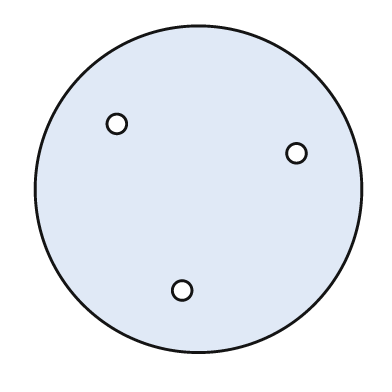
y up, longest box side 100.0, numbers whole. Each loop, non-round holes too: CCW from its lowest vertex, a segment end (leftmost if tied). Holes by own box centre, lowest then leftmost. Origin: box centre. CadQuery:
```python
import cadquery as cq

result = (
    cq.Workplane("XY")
    .moveTo(0.0, 0.0)
    .circle(50.0)
    .moveTo(-5.0, -31.0)
    .circle(3.0)
    .moveTo(30.0, 11.0)
    .circle(3.0)
    .moveTo(-25.0, 20.0)
    .circle(3.0)
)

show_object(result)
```